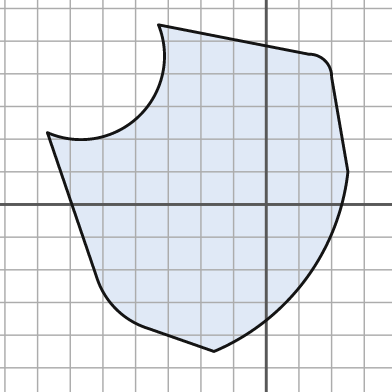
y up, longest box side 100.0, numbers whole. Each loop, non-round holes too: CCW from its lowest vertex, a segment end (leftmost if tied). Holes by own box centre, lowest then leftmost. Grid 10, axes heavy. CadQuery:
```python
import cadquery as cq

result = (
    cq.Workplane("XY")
    .moveTo(-16.0, -45.0)
    .threePointArc((12.0, -23.0), (25.0, 10.0))
    .lineTo(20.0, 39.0)
    .threePointArc((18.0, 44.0), (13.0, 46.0))
    .lineTo(-33.0, 55.0)
    .threePointArc((-39.0, 27.0), (-67.0, 22.0))
    .lineTo(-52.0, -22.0)
    .threePointArc((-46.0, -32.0), (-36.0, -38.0))
    .close()
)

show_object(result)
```